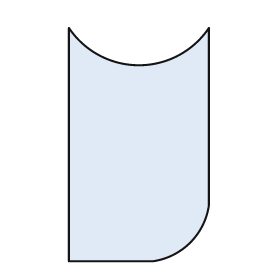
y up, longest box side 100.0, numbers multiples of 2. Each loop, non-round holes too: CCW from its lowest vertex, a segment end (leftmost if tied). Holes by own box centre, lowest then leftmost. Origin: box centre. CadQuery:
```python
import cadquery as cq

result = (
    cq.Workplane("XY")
    .moveTo(-30.0, -50.0)
    .lineTo(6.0, -50.0)
    .threePointArc((22.0, -42.0), (30.0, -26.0))
    .lineTo(30.0, 50.0)
    .threePointArc((0.0, 34.0), (-30.0, 50.0))
    .close()
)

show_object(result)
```